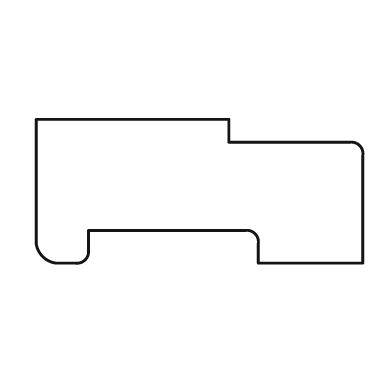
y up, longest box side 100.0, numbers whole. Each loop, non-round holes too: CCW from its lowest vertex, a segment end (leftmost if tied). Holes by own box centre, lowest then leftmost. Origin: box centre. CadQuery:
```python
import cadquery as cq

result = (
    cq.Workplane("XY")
    .moveTo(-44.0, -22.0)
    .lineTo(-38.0, -22.0)
    .threePointArc((-35.0, -21.0), (-34.0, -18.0))
    .lineTo(-34.0, -12.0)
    .lineTo(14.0, -12.0)
    .threePointArc((17.0, -13.0), (18.0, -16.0))
    .lineTo(18.0, -22.0)
    .lineTo(50.0, -22.0)
    .lineTo(50.0, 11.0)
    .threePointArc((49.0, 14.0), (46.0, 15.0))
    .lineTo(9.0, 15.0)
    .lineTo(9.0, 22.0)
    .lineTo(-50.0, 22.0)
    .lineTo(-50.0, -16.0)
    .threePointArc((-48.0, -20.0), (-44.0, -22.0))
    .close()
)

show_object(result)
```